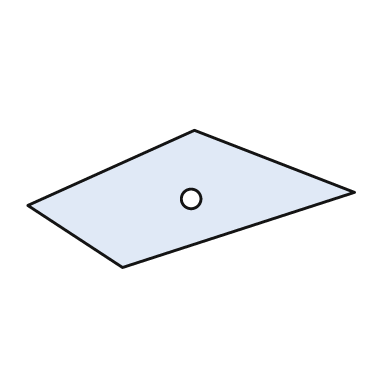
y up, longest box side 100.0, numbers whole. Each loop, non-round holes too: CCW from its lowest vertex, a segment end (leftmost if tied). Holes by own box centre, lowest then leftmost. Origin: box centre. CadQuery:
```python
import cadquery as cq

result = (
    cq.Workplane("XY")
    .moveTo(-21.0, -21.0)
    .lineTo(50.0, 2.0)
    .lineTo(1.0, 21.0)
    .lineTo(-50.0, -2.0)
    .close()
    .moveTo(0.0, 0.0)
    .circle(3.0)
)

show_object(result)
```